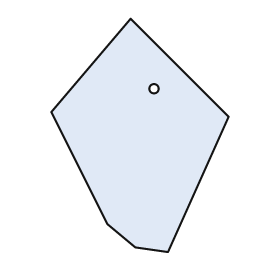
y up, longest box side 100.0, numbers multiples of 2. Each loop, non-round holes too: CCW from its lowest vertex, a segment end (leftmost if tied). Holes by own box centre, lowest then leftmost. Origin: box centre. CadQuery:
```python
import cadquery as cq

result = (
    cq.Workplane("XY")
    .moveTo(12.0, -50.0)
    .lineTo(38.0, 8.0)
    .lineTo(-4.0, 50.0)
    .lineTo(-38.0, 10.0)
    .lineTo(-14.0, -38.0)
    .lineTo(-2.0, -48.0)
    .close()
    .moveTo(6.0, 20.0)
    .circle(2.0)
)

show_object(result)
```